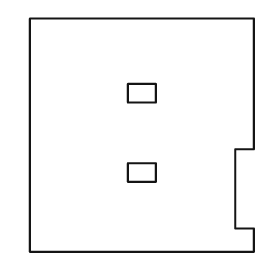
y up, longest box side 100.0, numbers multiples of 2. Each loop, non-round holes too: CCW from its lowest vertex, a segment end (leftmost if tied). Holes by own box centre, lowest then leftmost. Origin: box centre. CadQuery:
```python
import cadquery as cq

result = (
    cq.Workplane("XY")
    .moveTo(-48.0, -50.0)
    .lineTo(48.0, -50.0)
    .lineTo(48.0, -40.0)
    .lineTo(40.0, -40.0)
    .lineTo(40.0, -6.0)
    .lineTo(48.0, -6.0)
    .lineTo(48.0, 50.0)
    .lineTo(-48.0, 50.0)
    .close()
    .moveTo(-6.0, -20.0)
    .lineTo(6.0, -20.0)
    .lineTo(6.0, -12.0)
    .lineTo(-6.0, -12.0)
    .close()
    .moveTo(-6.0, 14.0)
    .lineTo(6.0, 14.0)
    .lineTo(6.0, 22.0)
    .lineTo(-6.0, 22.0)
    .close()
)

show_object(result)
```